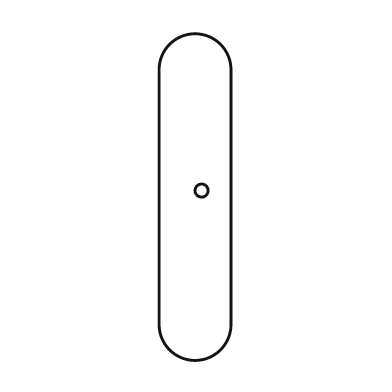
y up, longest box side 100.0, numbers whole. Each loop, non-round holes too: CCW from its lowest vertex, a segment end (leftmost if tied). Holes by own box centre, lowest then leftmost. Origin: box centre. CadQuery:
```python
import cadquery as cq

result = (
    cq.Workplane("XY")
    .moveTo(-11.0, -39.0)
    .threePointArc((0.0, -50.0), (11.0, -39.0))
    .lineTo(11.0, 39.0)
    .threePointArc((0.0, 50.0), (-11.0, 39.0))
    .close()
    .moveTo(2.0, 2.0)
    .circle(2.0)
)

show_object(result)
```